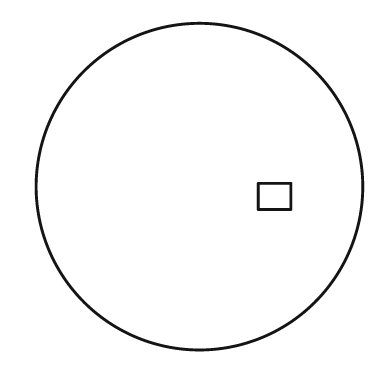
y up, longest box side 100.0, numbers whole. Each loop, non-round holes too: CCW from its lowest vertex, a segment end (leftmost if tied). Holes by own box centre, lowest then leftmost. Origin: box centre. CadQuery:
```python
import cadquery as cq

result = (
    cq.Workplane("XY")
    .moveTo(0.0, 0.0)
    .circle(50.0)
    .moveTo(18.0, -7.0)
    .lineTo(28.0, -7.0)
    .lineTo(28.0, 1.0)
    .lineTo(18.0, 1.0)
    .close()
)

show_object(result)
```